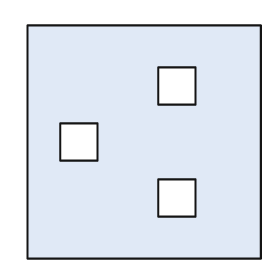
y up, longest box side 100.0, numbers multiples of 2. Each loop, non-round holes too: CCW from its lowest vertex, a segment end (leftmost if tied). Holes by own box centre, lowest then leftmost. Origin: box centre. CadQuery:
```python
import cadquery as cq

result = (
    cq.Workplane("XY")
    .moveTo(-50.0, -50.0)
    .lineTo(50.0, -50.0)
    .lineTo(50.0, 50.0)
    .lineTo(-50.0, 50.0)
    .close()
    .moveTo(6.0, -32.0)
    .lineTo(22.0, -32.0)
    .lineTo(22.0, -16.0)
    .lineTo(6.0, -16.0)
    .close()
    .moveTo(-36.0, -8.0)
    .lineTo(-20.0, -8.0)
    .lineTo(-20.0, 8.0)
    .lineTo(-36.0, 8.0)
    .close()
    .moveTo(6.0, 16.0)
    .lineTo(22.0, 16.0)
    .lineTo(22.0, 32.0)
    .lineTo(6.0, 32.0)
    .close()
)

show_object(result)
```